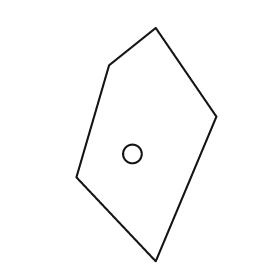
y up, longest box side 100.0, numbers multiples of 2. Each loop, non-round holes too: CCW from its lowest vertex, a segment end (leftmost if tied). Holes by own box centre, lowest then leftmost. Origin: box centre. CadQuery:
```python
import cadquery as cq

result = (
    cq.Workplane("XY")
    .moveTo(4.0, -50.0)
    .lineTo(30.0, 12.0)
    .lineTo(4.0, 50.0)
    .lineTo(-16.0, 34.0)
    .lineTo(-30.0, -14.0)
    .close()
    .moveTo(-6.0, -4.0)
    .circle(4.0)
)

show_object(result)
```